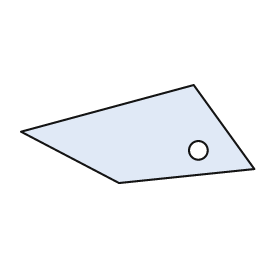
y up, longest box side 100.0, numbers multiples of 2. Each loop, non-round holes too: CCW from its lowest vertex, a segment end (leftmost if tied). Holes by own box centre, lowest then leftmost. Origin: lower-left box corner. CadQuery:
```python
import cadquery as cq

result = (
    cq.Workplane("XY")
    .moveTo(42.0, 0.0)
    .lineTo(100.0, 6.0)
    .lineTo(74.0, 42.0)
    .lineTo(0.0, 22.0)
    .close()
    .moveTo(76.0, 14.0)
    .circle(4.0)
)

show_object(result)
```